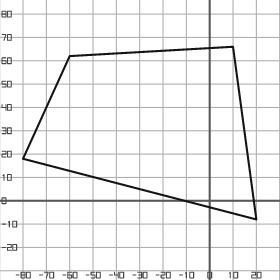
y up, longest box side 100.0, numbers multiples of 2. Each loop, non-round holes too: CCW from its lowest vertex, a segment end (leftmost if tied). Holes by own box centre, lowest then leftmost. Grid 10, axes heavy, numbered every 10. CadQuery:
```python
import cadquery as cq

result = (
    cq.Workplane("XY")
    .moveTo(20.0, -8.0)
    .lineTo(10.0, 66.0)
    .lineTo(-60.0, 62.0)
    .lineTo(-80.0, 18.0)
    .close()
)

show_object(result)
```